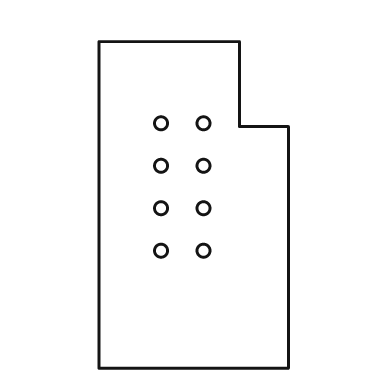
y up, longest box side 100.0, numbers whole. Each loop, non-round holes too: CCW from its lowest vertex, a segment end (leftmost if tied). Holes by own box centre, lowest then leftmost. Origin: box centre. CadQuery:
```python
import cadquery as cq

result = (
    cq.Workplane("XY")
    .moveTo(-29.0, -50.0)
    .lineTo(29.0, -50.0)
    .lineTo(29.0, 24.0)
    .lineTo(14.0, 24.0)
    .lineTo(14.0, 50.0)
    .lineTo(-29.0, 50.0)
    .close()
    .moveTo(-10.0, -14.0)
    .circle(2.0)
    .moveTo(3.0, -14.0)
    .circle(2.0)
    .moveTo(-10.0, -1.0)
    .circle(2.0)
    .moveTo(3.0, -1.0)
    .circle(2.0)
    .moveTo(-10.0, 12.0)
    .circle(2.0)
    .moveTo(3.0, 12.0)
    .circle(2.0)
    .moveTo(-10.0, 25.0)
    .circle(2.0)
    .moveTo(3.0, 25.0)
    .circle(2.0)
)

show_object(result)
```